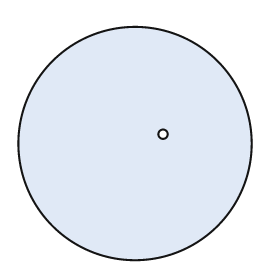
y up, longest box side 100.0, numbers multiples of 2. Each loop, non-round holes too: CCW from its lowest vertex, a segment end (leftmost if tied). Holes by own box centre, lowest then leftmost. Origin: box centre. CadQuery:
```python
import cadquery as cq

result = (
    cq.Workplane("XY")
    .moveTo(0.0, 0.0)
    .circle(50.0)
    .moveTo(12.0, 4.0)
    .circle(2.0)
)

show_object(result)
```